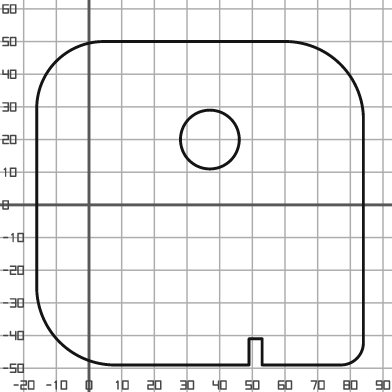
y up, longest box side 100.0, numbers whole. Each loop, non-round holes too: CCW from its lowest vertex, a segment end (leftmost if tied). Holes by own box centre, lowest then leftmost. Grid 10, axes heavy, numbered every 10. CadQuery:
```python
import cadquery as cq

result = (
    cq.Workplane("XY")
    .moveTo(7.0, -49.0)
    .lineTo(49.0, -49.0)
    .lineTo(49.0, -41.0)
    .lineTo(53.0, -41.0)
    .lineTo(53.0, -49.0)
    .lineTo(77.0, -49.0)
    .threePointArc((82.0, -47.0), (84.0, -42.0))
    .lineTo(84.0, 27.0)
    .threePointArc((77.0, 43.0), (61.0, 50.0))
    .lineTo(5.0, 50.0)
    .threePointArc((-10.0, 44.0), (-16.0, 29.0))
    .lineTo(-16.0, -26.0)
    .threePointArc((-9.0, -42.0), (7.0, -49.0))
    .close()
    .moveTo(37.0, 20.0)
    .circle(9.0)
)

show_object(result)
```